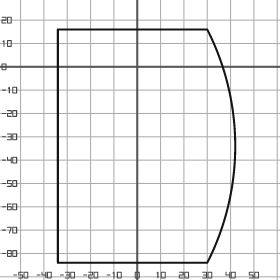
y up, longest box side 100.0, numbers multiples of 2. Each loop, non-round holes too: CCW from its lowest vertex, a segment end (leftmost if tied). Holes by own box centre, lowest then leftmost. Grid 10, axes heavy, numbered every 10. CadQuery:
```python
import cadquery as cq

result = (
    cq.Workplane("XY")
    .moveTo(-34.0, -84.0)
    .lineTo(30.0, -84.0)
    .threePointArc((42.0, -34.0), (30.0, 16.0))
    .lineTo(-34.0, 16.0)
    .close()
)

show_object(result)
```